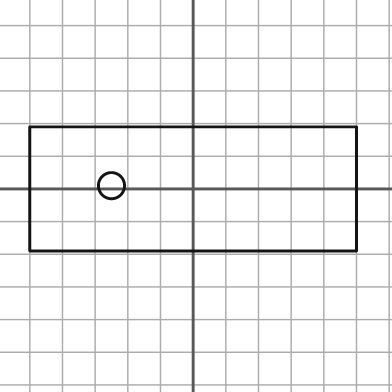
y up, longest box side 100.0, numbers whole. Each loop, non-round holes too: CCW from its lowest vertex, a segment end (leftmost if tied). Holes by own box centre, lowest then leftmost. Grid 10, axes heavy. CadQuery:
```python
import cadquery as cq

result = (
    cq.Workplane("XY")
    .moveTo(-50.0, -19.0)
    .lineTo(50.0, -19.0)
    .lineTo(50.0, 19.0)
    .lineTo(-50.0, 19.0)
    .close()
    .moveTo(-25.0, 1.0)
    .circle(4.0)
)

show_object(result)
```